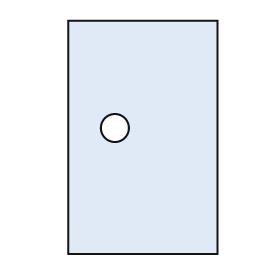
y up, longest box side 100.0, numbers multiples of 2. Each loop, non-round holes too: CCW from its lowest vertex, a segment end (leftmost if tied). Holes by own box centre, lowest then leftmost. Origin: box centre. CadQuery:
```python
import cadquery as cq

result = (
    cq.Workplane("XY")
    .moveTo(-32.0, -50.0)
    .lineTo(32.0, -50.0)
    .lineTo(32.0, 50.0)
    .lineTo(-32.0, 50.0)
    .close()
    .moveTo(-12.0, 4.0)
    .circle(6.0)
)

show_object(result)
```